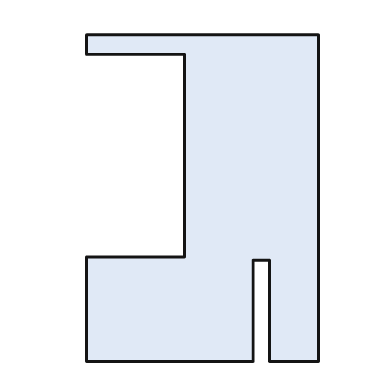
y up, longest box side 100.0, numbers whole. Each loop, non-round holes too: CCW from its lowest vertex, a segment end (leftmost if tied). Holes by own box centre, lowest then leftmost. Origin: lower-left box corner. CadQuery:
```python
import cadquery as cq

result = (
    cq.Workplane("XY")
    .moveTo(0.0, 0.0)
    .lineTo(51.0, 0.0)
    .lineTo(51.0, 31.0)
    .lineTo(56.0, 31.0)
    .lineTo(56.0, 0.0)
    .lineTo(71.0, 0.0)
    .lineTo(71.0, 100.0)
    .lineTo(0.0, 100.0)
    .lineTo(0.0, 94.0)
    .lineTo(30.0, 94.0)
    .lineTo(30.0, 32.0)
    .lineTo(0.0, 32.0)
    .close()
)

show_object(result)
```